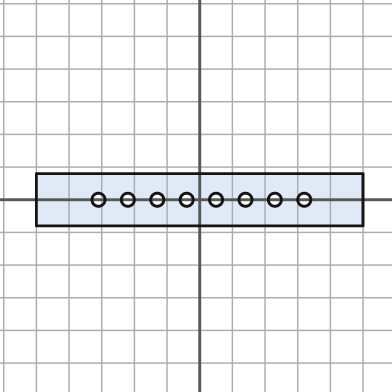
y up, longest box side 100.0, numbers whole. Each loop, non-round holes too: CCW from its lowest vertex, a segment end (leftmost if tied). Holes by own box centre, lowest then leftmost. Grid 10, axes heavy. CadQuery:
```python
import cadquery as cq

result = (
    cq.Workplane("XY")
    .moveTo(-50.0, -8.0)
    .lineTo(50.0, -8.0)
    .lineTo(50.0, 8.0)
    .lineTo(-50.0, 8.0)
    .close()
    .moveTo(-31.0, 0.0)
    .circle(2.0)
    .moveTo(-22.0, 0.0)
    .circle(2.0)
    .moveTo(-13.0, 0.0)
    .circle(2.0)
    .moveTo(-4.0, 0.0)
    .circle(2.0)
    .moveTo(5.0, 0.0)
    .circle(2.0)
    .moveTo(14.0, 0.0)
    .circle(2.0)
    .moveTo(23.0, 0.0)
    .circle(2.0)
    .moveTo(32.0, 0.0)
    .circle(2.0)
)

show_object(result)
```